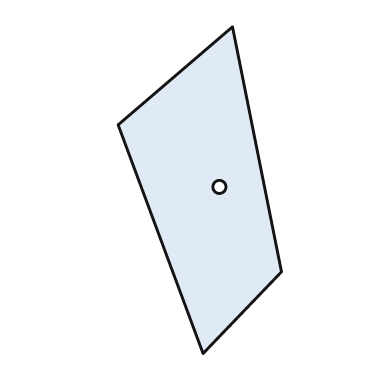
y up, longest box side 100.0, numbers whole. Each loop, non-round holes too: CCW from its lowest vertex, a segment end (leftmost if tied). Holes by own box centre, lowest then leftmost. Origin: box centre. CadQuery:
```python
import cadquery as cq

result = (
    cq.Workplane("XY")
    .moveTo(1.0, -50.0)
    .lineTo(25.0, -25.0)
    .lineTo(10.0, 50.0)
    .lineTo(-25.0, 20.0)
    .close()
    .moveTo(6.0, 1.0)
    .circle(2.0)
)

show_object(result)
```